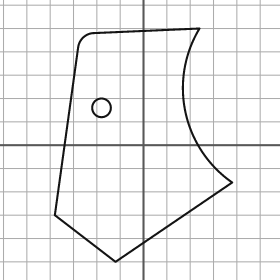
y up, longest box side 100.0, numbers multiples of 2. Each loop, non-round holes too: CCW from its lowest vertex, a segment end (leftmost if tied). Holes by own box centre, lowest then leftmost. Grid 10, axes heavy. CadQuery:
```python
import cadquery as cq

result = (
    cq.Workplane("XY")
    .moveTo(-12.0, -50.0)
    .lineTo(38.0, -16.0)
    .threePointArc((18.0, 14.0), (24.0, 50.0))
    .lineTo(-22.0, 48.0)
    .threePointArc((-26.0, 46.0), (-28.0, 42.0))
    .lineTo(-38.0, -30.0)
    .close()
    .moveTo(-18.0, 16.0)
    .circle(4.0)
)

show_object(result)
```